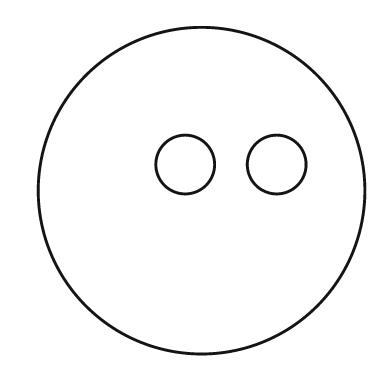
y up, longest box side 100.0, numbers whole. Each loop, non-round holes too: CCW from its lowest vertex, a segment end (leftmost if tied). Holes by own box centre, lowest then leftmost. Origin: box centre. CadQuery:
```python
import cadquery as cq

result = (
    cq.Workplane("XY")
    .moveTo(0.0, 0.0)
    .circle(50.0)
    .moveTo(-5.0, 8.0)
    .circle(9.0)
    .moveTo(23.0, 8.0)
    .circle(9.0)
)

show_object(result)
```